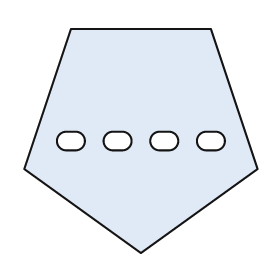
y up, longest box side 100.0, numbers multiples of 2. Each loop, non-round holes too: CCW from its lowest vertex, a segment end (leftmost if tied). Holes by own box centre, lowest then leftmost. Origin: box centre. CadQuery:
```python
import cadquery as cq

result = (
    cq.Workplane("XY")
    .moveTo(0.0, -48.0)
    .lineTo(50.0, -12.0)
    .lineTo(30.0, 48.0)
    .lineTo(-30.0, 48.0)
    .lineTo(-50.0, -12.0)
    .close()
    .moveTo(-32.0, -4.0)
    .lineTo(-28.0, -4.0)
    .threePointArc((-24.0, 0.0), (-28.0, 4.0))
    .lineTo(-32.0, 4.0)
    .threePointArc((-36.0, 0.0), (-32.0, -4.0))
    .close()
    .moveTo(-12.0, -4.0)
    .lineTo(-8.0, -4.0)
    .threePointArc((-4.0, 0.0), (-8.0, 4.0))
    .lineTo(-12.0, 4.0)
    .threePointArc((-16.0, 0.0), (-12.0, -4.0))
    .close()
    .moveTo(8.0, -4.0)
    .lineTo(12.0, -4.0)
    .threePointArc((16.0, 0.0), (12.0, 4.0))
    .lineTo(8.0, 4.0)
    .threePointArc((4.0, 0.0), (8.0, -4.0))
    .close()
    .moveTo(28.0, -4.0)
    .lineTo(32.0, -4.0)
    .threePointArc((36.0, 0.0), (32.0, 4.0))
    .lineTo(28.0, 4.0)
    .threePointArc((24.0, 0.0), (28.0, -4.0))
    .close()
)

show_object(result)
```